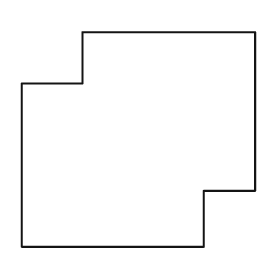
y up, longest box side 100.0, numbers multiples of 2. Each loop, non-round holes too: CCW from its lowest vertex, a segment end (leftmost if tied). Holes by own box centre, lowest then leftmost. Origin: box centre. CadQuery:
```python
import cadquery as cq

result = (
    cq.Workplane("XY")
    .moveTo(-50.0, -46.0)
    .lineTo(28.0, -46.0)
    .lineTo(28.0, -22.0)
    .lineTo(50.0, -22.0)
    .lineTo(50.0, 46.0)
    .lineTo(-24.0, 46.0)
    .lineTo(-24.0, 24.0)
    .lineTo(-50.0, 24.0)
    .close()
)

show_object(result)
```